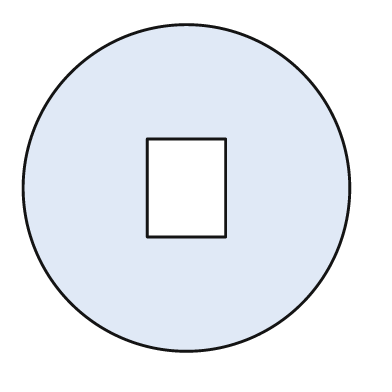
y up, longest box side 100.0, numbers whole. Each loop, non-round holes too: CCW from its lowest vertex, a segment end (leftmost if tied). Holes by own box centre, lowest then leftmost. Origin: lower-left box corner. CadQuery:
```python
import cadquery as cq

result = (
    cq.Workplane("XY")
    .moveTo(50.0, 50.0)
    .circle(50.0)
    .moveTo(38.0, 35.0)
    .lineTo(62.0, 35.0)
    .lineTo(62.0, 65.0)
    .lineTo(38.0, 65.0)
    .close()
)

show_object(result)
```